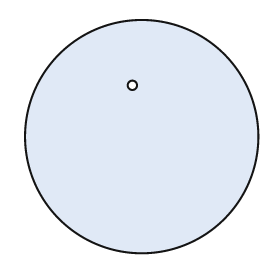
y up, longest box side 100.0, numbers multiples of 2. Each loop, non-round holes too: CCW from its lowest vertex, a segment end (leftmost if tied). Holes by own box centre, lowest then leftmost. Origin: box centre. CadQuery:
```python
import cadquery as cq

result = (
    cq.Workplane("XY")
    .moveTo(0.0, 0.0)
    .circle(50.0)
    .moveTo(-4.0, 22.0)
    .circle(2.0)
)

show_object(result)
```